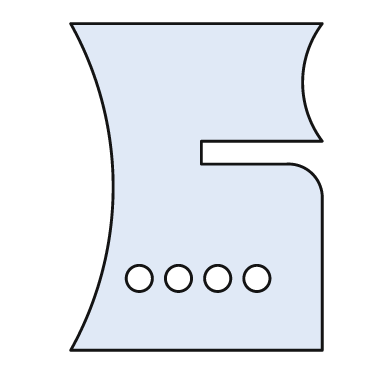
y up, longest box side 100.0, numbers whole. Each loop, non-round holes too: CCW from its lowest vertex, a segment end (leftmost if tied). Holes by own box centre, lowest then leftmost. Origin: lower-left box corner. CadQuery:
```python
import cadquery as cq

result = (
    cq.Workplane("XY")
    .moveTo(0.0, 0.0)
    .lineTo(77.0, 0.0)
    .lineTo(77.0, 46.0)
    .threePointArc((74.0, 54.0), (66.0, 57.0))
    .lineTo(40.0, 57.0)
    .lineTo(40.0, 64.0)
    .lineTo(77.0, 64.0)
    .threePointArc((71.0, 82.0), (77.0, 100.0))
    .lineTo(0.0, 100.0)
    .threePointArc((13.0, 50.0), (0.0, 0.0))
    .close()
    .moveTo(21.0, 22.0)
    .circle(4.0)
    .moveTo(33.0, 22.0)
    .circle(4.0)
    .moveTo(45.0, 22.0)
    .circle(4.0)
    .moveTo(57.0, 22.0)
    .circle(4.0)
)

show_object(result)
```